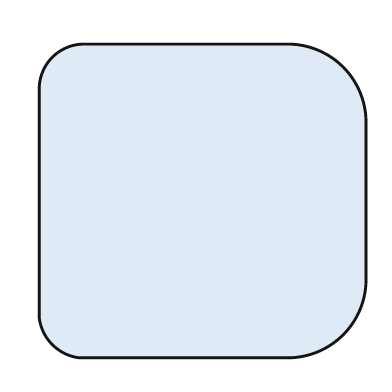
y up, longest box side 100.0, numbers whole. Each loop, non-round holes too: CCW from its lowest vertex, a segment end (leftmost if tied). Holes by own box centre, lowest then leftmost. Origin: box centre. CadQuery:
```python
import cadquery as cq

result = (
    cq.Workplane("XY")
    .moveTo(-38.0, -48.0)
    .lineTo(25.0, -48.0)
    .threePointArc((43.0, -41.0), (50.0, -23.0))
    .lineTo(50.0, 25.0)
    .threePointArc((43.0, 41.0), (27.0, 48.0))
    .lineTo(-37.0, 48.0)
    .threePointArc((-46.0, 44.0), (-50.0, 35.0))
    .lineTo(-50.0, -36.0)
    .threePointArc((-46.0, -44.0), (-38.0, -48.0))
    .close()
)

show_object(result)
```